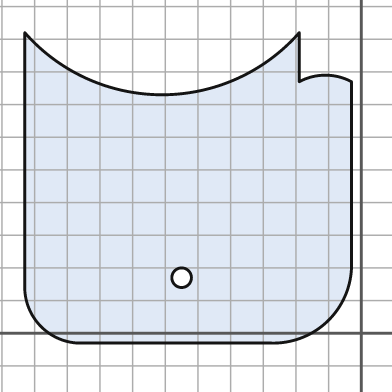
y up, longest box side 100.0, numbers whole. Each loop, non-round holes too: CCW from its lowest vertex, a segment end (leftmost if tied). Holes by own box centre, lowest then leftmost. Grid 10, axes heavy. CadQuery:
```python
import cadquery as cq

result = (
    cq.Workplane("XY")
    .moveTo(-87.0, -3.0)
    .lineTo(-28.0, -3.0)
    .threePointArc((-10.0, 4.0), (-3.0, 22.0))
    .lineTo(-3.0, 77.0)
    .threePointArc((-11.0, 79.0), (-19.0, 77.0))
    .lineTo(-19.0, 92.0)
    .threePointArc((-61.0, 73.0), (-103.0, 92.0))
    .lineTo(-103.0, 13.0)
    .threePointArc((-98.0, 2.0), (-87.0, -3.0))
    .close()
    .moveTo(-55.0, 17.0)
    .circle(3.0)
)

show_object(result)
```